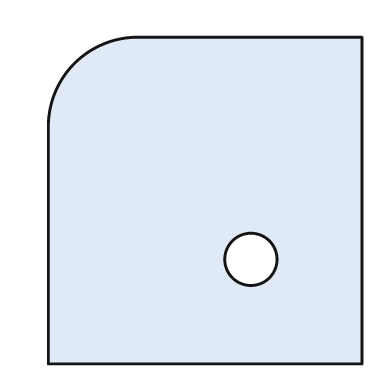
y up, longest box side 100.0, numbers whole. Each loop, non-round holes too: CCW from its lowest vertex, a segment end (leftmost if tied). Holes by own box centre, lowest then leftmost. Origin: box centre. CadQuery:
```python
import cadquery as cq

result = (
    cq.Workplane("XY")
    .moveTo(-48.0, -50.0)
    .lineTo(48.0, -50.0)
    .lineTo(48.0, 50.0)
    .lineTo(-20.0, 50.0)
    .threePointArc((-40.0, 42.0), (-48.0, 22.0))
    .close()
    .moveTo(14.0, -18.0)
    .circle(8.0)
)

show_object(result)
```